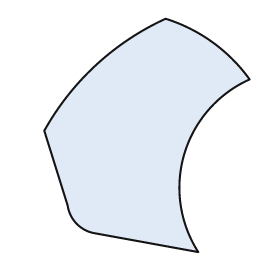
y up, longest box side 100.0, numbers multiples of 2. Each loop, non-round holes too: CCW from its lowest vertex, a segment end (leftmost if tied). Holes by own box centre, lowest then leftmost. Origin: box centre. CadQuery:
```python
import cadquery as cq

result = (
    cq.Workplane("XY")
    .moveTo(22.0, -50.0)
    .threePointArc((16.0, -8.0), (44.0, 24.0))
    .threePointArc((28.0, 40.0), (8.0, 50.0))
    .threePointArc((-22.0, 30.0), (-44.0, 2.0))
    .lineTo(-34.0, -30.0)
    .threePointArc((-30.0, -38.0), (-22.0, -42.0))
    .close()
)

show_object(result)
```